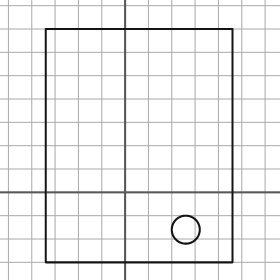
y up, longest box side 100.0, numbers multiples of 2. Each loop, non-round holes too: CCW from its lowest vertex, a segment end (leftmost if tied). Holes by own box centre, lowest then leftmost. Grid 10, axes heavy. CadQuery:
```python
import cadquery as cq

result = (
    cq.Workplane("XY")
    .moveTo(-34.0, -30.0)
    .lineTo(46.0, -30.0)
    .lineTo(46.0, 70.0)
    .lineTo(-34.0, 70.0)
    .close()
    .moveTo(26.0, -16.0)
    .circle(6.0)
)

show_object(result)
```